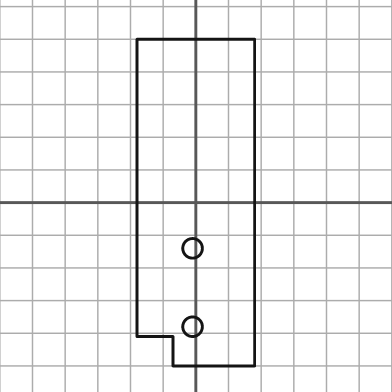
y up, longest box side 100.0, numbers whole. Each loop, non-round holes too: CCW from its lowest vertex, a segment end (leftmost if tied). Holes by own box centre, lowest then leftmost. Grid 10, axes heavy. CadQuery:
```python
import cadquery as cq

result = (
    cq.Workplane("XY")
    .moveTo(-7.0, -50.0)
    .lineTo(18.0, -50.0)
    .lineTo(18.0, 50.0)
    .lineTo(-18.0, 50.0)
    .lineTo(-18.0, -41.0)
    .lineTo(-7.0, -41.0)
    .close()
    .moveTo(-1.0, -38.0)
    .circle(3.0)
    .moveTo(-1.0, -14.0)
    .circle(3.0)
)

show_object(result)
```